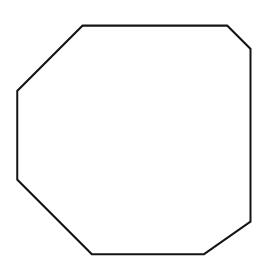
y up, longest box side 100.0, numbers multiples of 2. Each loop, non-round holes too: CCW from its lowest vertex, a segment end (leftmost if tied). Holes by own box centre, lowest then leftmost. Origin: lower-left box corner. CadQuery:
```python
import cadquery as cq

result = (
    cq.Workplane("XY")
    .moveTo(32.0, 0.0)
    .lineTo(80.0, 0.0)
    .lineTo(100.0, 14.0)
    .lineTo(100.0, 88.0)
    .lineTo(90.0, 98.0)
    .lineTo(28.0, 98.0)
    .lineTo(0.0, 70.0)
    .lineTo(0.0, 32.0)
    .close()
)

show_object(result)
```